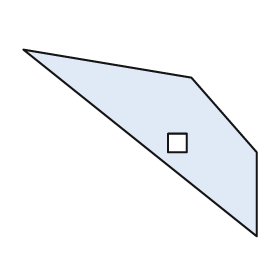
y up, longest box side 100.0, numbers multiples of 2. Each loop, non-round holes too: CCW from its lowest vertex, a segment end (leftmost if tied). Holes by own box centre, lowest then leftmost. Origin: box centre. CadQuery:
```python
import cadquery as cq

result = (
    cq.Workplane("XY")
    .moveTo(50.0, -40.0)
    .lineTo(50.0, -4.0)
    .lineTo(22.0, 28.0)
    .lineTo(-50.0, 40.0)
    .close()
    .moveTo(12.0, -4.0)
    .lineTo(20.0, -4.0)
    .lineTo(20.0, 4.0)
    .lineTo(12.0, 4.0)
    .close()
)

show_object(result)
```